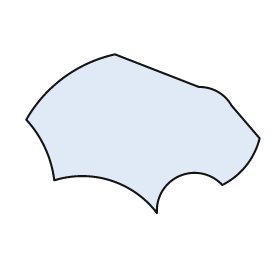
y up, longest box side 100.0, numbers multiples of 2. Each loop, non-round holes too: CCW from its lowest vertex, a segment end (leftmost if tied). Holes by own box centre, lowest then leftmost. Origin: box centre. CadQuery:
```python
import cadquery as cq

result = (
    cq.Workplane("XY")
    .moveTo(6.0, -34.0)
    .threePointArc((16.0, -18.0), (34.0, -22.0))
    .threePointArc((44.0, -14.0), (50.0, -2.0))
    .lineTo(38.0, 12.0)
    .threePointArc((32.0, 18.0), (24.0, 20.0))
    .lineTo(-12.0, 34.0)
    .threePointArc((-34.0, 24.0), (-50.0, 6.0))
    .threePointArc((-42.0, -6.0), (-38.0, -20.0))
    .threePointArc((-14.0, -20.0), (6.0, -34.0))
    .close()
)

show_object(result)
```